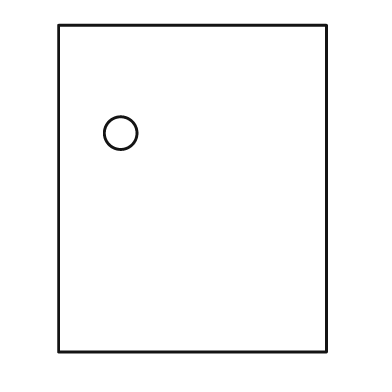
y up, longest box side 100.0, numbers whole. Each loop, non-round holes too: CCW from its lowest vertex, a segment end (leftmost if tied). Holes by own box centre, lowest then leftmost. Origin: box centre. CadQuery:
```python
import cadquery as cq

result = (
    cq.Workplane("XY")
    .moveTo(-41.0, -50.0)
    .lineTo(41.0, -50.0)
    .lineTo(41.0, 50.0)
    .lineTo(-41.0, 50.0)
    .close()
    .moveTo(-22.0, 17.0)
    .circle(5.0)
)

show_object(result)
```